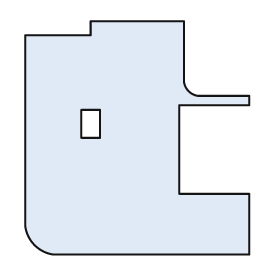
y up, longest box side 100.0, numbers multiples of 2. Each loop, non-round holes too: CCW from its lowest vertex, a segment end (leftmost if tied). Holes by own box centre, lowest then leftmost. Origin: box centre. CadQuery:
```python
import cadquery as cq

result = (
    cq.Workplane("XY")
    .moveTo(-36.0, -50.0)
    .lineTo(48.0, -50.0)
    .lineTo(48.0, -24.0)
    .lineTo(18.0, -24.0)
    .lineTo(18.0, 14.0)
    .lineTo(48.0, 14.0)
    .lineTo(48.0, 18.0)
    .lineTo(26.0, 18.0)
    .threePointArc((22.0, 20.0), (20.0, 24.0))
    .lineTo(20.0, 50.0)
    .lineTo(-20.0, 50.0)
    .lineTo(-20.0, 44.0)
    .lineTo(-48.0, 44.0)
    .lineTo(-48.0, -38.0)
    .threePointArc((-44.0, -46.0), (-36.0, -50.0))
    .close()
    .moveTo(-24.0, 0.0)
    .lineTo(-16.0, 0.0)
    .lineTo(-16.0, 12.0)
    .lineTo(-24.0, 12.0)
    .close()
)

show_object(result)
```